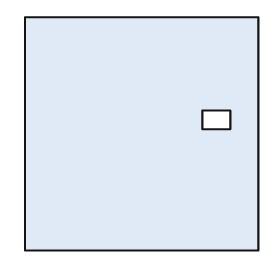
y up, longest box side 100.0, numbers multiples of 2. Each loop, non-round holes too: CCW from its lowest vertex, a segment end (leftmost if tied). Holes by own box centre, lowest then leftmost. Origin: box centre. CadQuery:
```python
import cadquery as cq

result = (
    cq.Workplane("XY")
    .moveTo(-50.0, -50.0)
    .lineTo(50.0, -50.0)
    .lineTo(50.0, 50.0)
    .lineTo(-50.0, 50.0)
    .close()
    .moveTo(26.0, 2.0)
    .lineTo(38.0, 2.0)
    .lineTo(38.0, 10.0)
    .lineTo(26.0, 10.0)
    .close()
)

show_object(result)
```